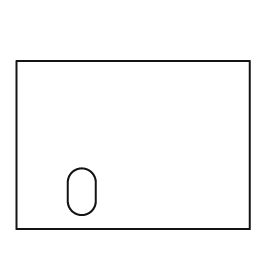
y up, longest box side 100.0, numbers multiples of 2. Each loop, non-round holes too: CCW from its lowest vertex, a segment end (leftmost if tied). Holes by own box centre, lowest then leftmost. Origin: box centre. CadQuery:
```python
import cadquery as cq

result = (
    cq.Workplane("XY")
    .moveTo(-50.0, -36.0)
    .lineTo(50.0, -36.0)
    .lineTo(50.0, 36.0)
    .lineTo(-50.0, 36.0)
    .close()
    .moveTo(-28.0, -24.0)
    .threePointArc((-22.0, -30.0), (-16.0, -24.0))
    .lineTo(-16.0, -16.0)
    .threePointArc((-22.0, -10.0), (-28.0, -16.0))
    .close()
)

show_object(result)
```